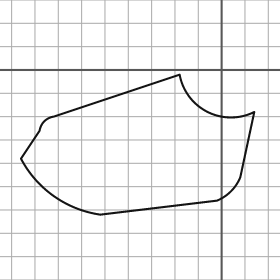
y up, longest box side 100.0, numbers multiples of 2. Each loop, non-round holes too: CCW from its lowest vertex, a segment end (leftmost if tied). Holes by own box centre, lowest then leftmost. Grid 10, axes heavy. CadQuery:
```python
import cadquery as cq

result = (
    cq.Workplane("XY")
    .moveTo(-52.0, -62.0)
    .lineTo(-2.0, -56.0)
    .threePointArc((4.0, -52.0), (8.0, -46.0))
    .lineTo(14.0, -18.0)
    .threePointArc((-6.0, -18.0), (-18.0, -2.0))
    .lineTo(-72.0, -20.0)
    .threePointArc((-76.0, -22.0), (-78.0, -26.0))
    .lineTo(-86.0, -38.0)
    .threePointArc((-72.0, -54.0), (-52.0, -62.0))
    .close()
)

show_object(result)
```